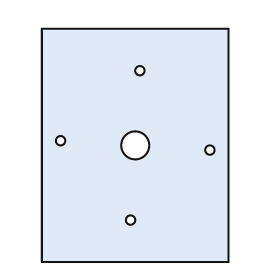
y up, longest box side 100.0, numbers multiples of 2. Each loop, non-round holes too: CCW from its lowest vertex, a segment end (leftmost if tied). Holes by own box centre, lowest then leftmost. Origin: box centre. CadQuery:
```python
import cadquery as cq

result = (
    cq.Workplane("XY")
    .moveTo(-40.0, -50.0)
    .lineTo(40.0, -50.0)
    .lineTo(40.0, 50.0)
    .lineTo(-40.0, 50.0)
    .close()
    .moveTo(-2.0, -32.0)
    .circle(2.0)
    .moveTo(32.0, -2.0)
    .circle(2.0)
    .moveTo(0.0, 0.0)
    .circle(6.0)
    .moveTo(-32.0, 2.0)
    .circle(2.0)
    .moveTo(2.0, 32.0)
    .circle(2.0)
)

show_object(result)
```